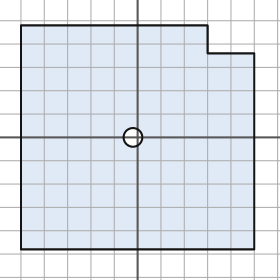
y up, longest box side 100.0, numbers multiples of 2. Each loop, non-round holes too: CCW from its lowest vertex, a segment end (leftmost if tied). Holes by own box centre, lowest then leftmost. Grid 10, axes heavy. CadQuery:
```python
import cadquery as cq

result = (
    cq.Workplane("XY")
    .moveTo(-50.0, -48.0)
    .lineTo(50.0, -48.0)
    .lineTo(50.0, 36.0)
    .lineTo(30.0, 36.0)
    .lineTo(30.0, 48.0)
    .lineTo(-50.0, 48.0)
    .close()
    .moveTo(-2.0, 0.0)
    .circle(4.0)
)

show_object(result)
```